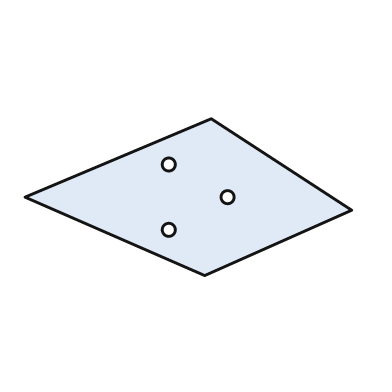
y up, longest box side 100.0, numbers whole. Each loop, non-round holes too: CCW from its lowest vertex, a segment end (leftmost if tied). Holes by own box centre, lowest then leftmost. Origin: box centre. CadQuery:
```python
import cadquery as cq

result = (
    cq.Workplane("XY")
    .moveTo(5.0, -24.0)
    .lineTo(50.0, -4.0)
    .lineTo(7.0, 24.0)
    .lineTo(-50.0, 0.0)
    .close()
    .moveTo(-6.0, -10.0)
    .circle(2.0)
    .moveTo(12.0, 0.0)
    .circle(2.0)
    .moveTo(-6.0, 10.0)
    .circle(2.0)
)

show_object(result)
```